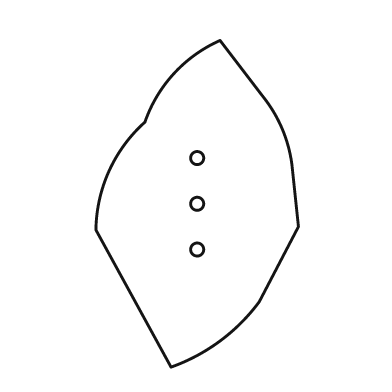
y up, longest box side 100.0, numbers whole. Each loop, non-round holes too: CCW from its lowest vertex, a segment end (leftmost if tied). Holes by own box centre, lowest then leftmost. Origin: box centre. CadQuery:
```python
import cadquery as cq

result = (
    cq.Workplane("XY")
    .moveTo(-8.0, -50.0)
    .threePointArc((7.0, -42.0), (19.0, -30.0))
    .lineTo(31.0, -7.0)
    .lineTo(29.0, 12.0)
    .threePointArc((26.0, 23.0), (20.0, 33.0))
    .lineTo(7.0, 50.0)
    .threePointArc((-7.0, 40.0), (-16.0, 25.0))
    .threePointArc((-27.0, 10.0), (-31.0, -8.0))
    .close()
    .moveTo(0.0, -14.0)
    .circle(2.0)
    .moveTo(0.0, 0.0)
    .circle(2.0)
    .moveTo(0.0, 14.0)
    .circle(2.0)
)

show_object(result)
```